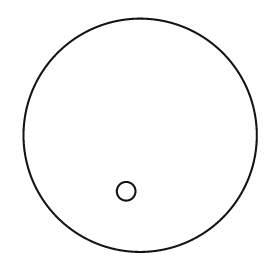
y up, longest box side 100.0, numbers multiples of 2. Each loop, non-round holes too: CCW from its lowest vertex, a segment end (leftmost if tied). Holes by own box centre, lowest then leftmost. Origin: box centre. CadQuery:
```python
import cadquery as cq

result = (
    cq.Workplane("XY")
    .moveTo(0.0, 0.0)
    .circle(50.0)
    .moveTo(-6.0, -24.0)
    .circle(4.0)
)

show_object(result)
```